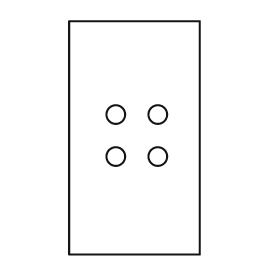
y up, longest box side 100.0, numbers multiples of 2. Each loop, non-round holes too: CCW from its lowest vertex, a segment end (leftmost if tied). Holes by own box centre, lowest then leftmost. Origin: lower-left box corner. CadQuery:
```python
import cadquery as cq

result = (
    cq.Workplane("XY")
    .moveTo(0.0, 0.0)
    .lineTo(56.0, 0.0)
    .lineTo(56.0, 100.0)
    .lineTo(0.0, 100.0)
    .close()
    .moveTo(20.0, 42.0)
    .circle(4.0)
    .moveTo(38.0, 42.0)
    .circle(4.0)
    .moveTo(20.0, 60.0)
    .circle(4.0)
    .moveTo(38.0, 60.0)
    .circle(4.0)
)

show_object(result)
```